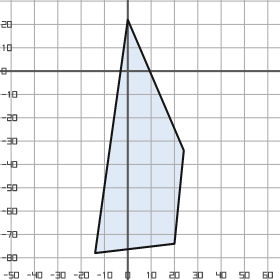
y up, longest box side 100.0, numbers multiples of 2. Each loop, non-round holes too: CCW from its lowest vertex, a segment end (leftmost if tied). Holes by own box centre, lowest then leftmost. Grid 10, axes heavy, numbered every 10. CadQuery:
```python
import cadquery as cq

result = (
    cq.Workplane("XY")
    .moveTo(-14.0, -78.0)
    .lineTo(20.0, -74.0)
    .lineTo(24.0, -34.0)
    .lineTo(0.0, 22.0)
    .close()
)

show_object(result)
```